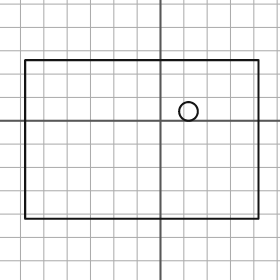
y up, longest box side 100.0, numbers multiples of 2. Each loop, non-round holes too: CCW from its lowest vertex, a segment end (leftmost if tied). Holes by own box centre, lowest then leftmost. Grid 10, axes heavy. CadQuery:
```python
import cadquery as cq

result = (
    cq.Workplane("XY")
    .moveTo(-58.0, -42.0)
    .lineTo(42.0, -42.0)
    .lineTo(42.0, 26.0)
    .lineTo(-58.0, 26.0)
    .close()
    .moveTo(12.0, 4.0)
    .circle(4.0)
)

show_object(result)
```